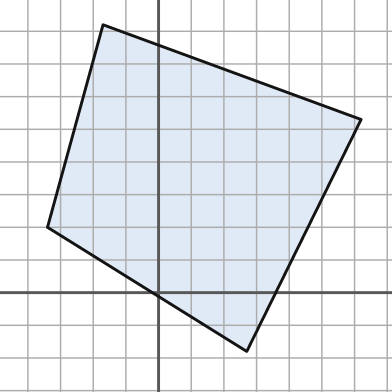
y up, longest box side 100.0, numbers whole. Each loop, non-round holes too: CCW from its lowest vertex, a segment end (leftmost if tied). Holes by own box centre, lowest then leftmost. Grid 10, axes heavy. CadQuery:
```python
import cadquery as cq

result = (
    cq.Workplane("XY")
    .moveTo(27.0, -18.0)
    .lineTo(62.0, 53.0)
    .lineTo(-17.0, 82.0)
    .lineTo(-34.0, 20.0)
    .close()
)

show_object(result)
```